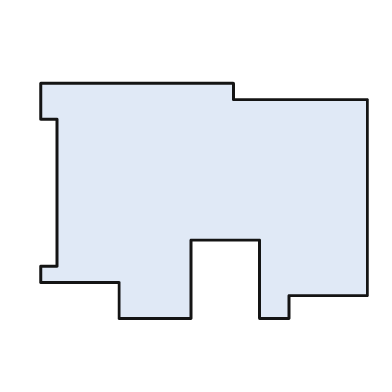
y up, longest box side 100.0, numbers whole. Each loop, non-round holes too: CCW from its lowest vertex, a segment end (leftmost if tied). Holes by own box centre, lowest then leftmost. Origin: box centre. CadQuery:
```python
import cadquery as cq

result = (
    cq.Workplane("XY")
    .moveTo(-26.0, -36.0)
    .lineTo(-4.0, -36.0)
    .lineTo(-4.0, -12.0)
    .lineTo(17.0, -12.0)
    .lineTo(17.0, -36.0)
    .lineTo(26.0, -36.0)
    .lineTo(26.0, -29.0)
    .lineTo(50.0, -29.0)
    .lineTo(50.0, 31.0)
    .lineTo(9.0, 31.0)
    .lineTo(9.0, 36.0)
    .lineTo(-50.0, 36.0)
    .lineTo(-50.0, 25.0)
    .lineTo(-45.0, 25.0)
    .lineTo(-45.0, -20.0)
    .lineTo(-50.0, -20.0)
    .lineTo(-50.0, -25.0)
    .lineTo(-26.0, -25.0)
    .close()
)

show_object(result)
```